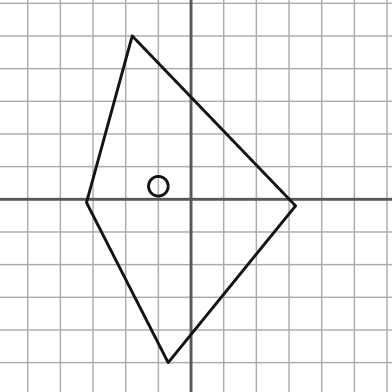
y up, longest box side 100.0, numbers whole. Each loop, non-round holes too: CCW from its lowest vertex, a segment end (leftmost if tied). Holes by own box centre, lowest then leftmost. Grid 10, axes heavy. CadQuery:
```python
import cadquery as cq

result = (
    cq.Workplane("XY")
    .moveTo(-7.0, -50.0)
    .lineTo(32.0, -2.0)
    .lineTo(-18.0, 50.0)
    .lineTo(-32.0, -1.0)
    .close()
    .moveTo(-10.0, 4.0)
    .circle(3.0)
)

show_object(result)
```